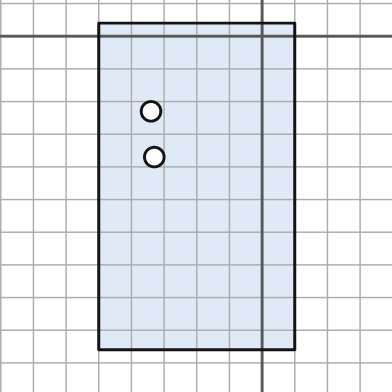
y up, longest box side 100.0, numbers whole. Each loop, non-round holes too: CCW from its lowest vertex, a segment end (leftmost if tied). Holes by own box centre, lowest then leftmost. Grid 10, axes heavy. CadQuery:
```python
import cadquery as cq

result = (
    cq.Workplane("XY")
    .moveTo(-50.0, -96.0)
    .lineTo(10.0, -96.0)
    .lineTo(10.0, 4.0)
    .lineTo(-50.0, 4.0)
    .close()
    .moveTo(-33.0, -37.0)
    .circle(3.0)
    .moveTo(-34.0, -23.0)
    .circle(3.0)
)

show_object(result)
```